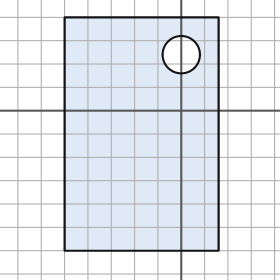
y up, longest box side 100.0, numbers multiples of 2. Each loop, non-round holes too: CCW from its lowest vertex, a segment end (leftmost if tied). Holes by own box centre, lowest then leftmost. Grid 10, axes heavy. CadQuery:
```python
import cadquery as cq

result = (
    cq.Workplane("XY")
    .moveTo(-50.0, -60.0)
    .lineTo(16.0, -60.0)
    .lineTo(16.0, 40.0)
    .lineTo(-50.0, 40.0)
    .close()
    .moveTo(0.0, 24.0)
    .circle(8.0)
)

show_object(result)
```